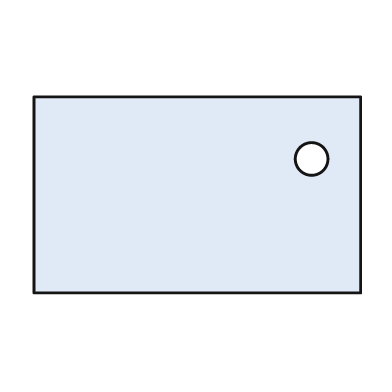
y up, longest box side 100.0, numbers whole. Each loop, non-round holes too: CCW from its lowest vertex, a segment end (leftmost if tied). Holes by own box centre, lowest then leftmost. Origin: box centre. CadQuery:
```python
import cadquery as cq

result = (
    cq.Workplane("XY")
    .moveTo(-50.0, -30.0)
    .lineTo(50.0, -30.0)
    .lineTo(50.0, 30.0)
    .lineTo(-50.0, 30.0)
    .close()
    .moveTo(35.0, 11.0)
    .circle(5.0)
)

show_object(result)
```